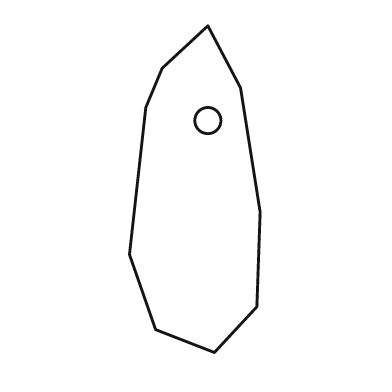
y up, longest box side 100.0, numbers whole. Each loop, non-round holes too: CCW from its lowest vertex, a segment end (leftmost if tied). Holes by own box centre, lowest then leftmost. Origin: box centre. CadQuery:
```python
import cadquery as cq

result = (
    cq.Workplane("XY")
    .moveTo(6.0, -50.0)
    .lineTo(19.0, -36.0)
    .lineTo(20.0, -7.0)
    .lineTo(14.0, 31.0)
    .lineTo(4.0, 50.0)
    .lineTo(-10.0, 37.0)
    .lineTo(-15.0, 25.0)
    .lineTo(-20.0, -20.0)
    .lineTo(-12.0, -43.0)
    .close()
    .moveTo(4.0, 21.0)
    .circle(4.0)
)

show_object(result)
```